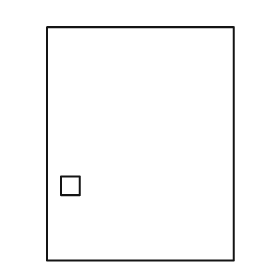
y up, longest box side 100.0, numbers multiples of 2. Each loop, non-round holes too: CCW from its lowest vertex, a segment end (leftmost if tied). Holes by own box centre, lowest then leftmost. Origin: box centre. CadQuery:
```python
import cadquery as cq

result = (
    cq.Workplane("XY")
    .moveTo(-40.0, -50.0)
    .lineTo(40.0, -50.0)
    .lineTo(40.0, 50.0)
    .lineTo(-40.0, 50.0)
    .close()
    .moveTo(-34.0, -22.0)
    .lineTo(-26.0, -22.0)
    .lineTo(-26.0, -14.0)
    .lineTo(-34.0, -14.0)
    .close()
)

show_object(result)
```